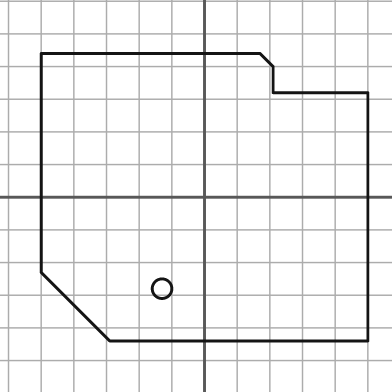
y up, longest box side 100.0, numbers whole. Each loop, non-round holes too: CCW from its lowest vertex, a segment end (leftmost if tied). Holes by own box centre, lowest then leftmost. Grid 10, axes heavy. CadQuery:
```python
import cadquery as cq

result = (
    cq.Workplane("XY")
    .moveTo(-29.0, -44.0)
    .lineTo(50.0, -44.0)
    .lineTo(50.0, 32.0)
    .lineTo(21.0, 32.0)
    .lineTo(21.0, 40.0)
    .lineTo(17.0, 44.0)
    .lineTo(-50.0, 44.0)
    .lineTo(-50.0, -23.0)
    .close()
    .moveTo(-13.0, -28.0)
    .circle(3.0)
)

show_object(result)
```